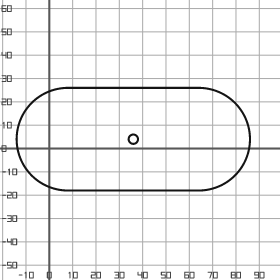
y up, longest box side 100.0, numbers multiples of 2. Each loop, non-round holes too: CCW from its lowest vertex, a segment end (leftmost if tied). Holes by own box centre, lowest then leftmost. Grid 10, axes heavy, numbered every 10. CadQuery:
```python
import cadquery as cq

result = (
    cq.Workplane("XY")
    .moveTo(8.0, -18.0)
    .lineTo(64.0, -18.0)
    .threePointArc((86.0, 4.0), (64.0, 26.0))
    .lineTo(8.0, 26.0)
    .threePointArc((-14.0, 4.0), (8.0, -18.0))
    .close()
    .moveTo(36.0, 4.0)
    .circle(2.0)
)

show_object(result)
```